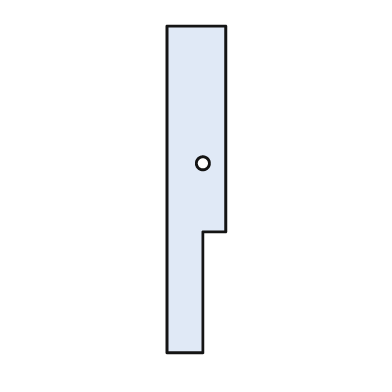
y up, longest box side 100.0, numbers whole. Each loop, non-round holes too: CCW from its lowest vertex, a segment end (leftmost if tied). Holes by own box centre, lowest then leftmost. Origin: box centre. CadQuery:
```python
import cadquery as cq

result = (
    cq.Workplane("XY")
    .moveTo(-9.0, -50.0)
    .lineTo(2.0, -50.0)
    .lineTo(2.0, -13.0)
    .lineTo(9.0, -13.0)
    .lineTo(9.0, 50.0)
    .lineTo(-9.0, 50.0)
    .close()
    .moveTo(2.0, 8.0)
    .circle(2.0)
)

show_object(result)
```